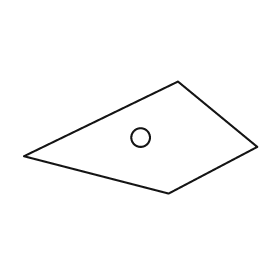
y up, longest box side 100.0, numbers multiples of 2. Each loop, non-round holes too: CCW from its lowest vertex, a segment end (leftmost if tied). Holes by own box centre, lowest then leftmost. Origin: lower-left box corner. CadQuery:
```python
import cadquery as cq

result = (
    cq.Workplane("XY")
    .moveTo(62.0, 0.0)
    .lineTo(100.0, 20.0)
    .lineTo(66.0, 48.0)
    .lineTo(0.0, 16.0)
    .close()
    .moveTo(50.0, 24.0)
    .circle(4.0)
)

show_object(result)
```